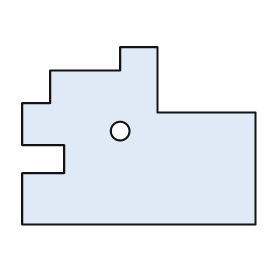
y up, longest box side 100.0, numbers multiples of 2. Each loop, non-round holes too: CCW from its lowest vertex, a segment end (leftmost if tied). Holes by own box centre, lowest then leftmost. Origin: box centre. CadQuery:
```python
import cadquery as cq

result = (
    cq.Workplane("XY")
    .moveTo(-50.0, -38.0)
    .lineTo(50.0, -38.0)
    .lineTo(50.0, 10.0)
    .lineTo(8.0, 10.0)
    .lineTo(8.0, 38.0)
    .lineTo(-8.0, 38.0)
    .lineTo(-8.0, 28.0)
    .lineTo(-38.0, 28.0)
    .lineTo(-38.0, 14.0)
    .lineTo(-50.0, 14.0)
    .lineTo(-50.0, -4.0)
    .lineTo(-32.0, -4.0)
    .lineTo(-32.0, -16.0)
    .lineTo(-50.0, -16.0)
    .close()
    .moveTo(-8.0, 2.0)
    .circle(4.0)
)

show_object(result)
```